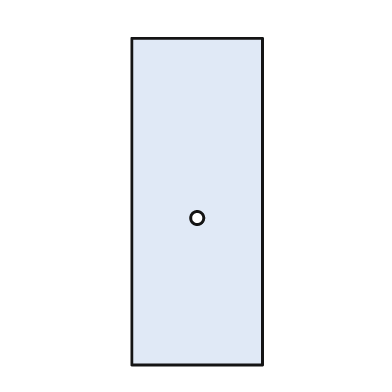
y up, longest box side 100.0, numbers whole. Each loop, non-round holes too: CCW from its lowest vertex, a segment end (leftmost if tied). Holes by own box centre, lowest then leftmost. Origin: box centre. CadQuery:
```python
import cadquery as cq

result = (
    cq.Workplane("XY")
    .moveTo(-20.0, -50.0)
    .lineTo(20.0, -50.0)
    .lineTo(20.0, 50.0)
    .lineTo(-20.0, 50.0)
    .close()
    .moveTo(0.0, -5.0)
    .circle(2.0)
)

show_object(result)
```